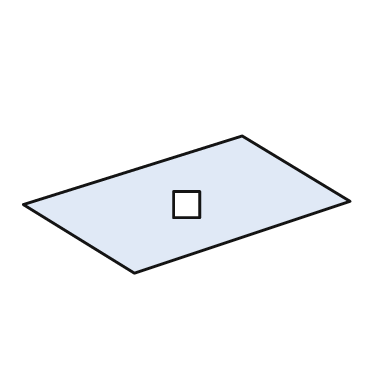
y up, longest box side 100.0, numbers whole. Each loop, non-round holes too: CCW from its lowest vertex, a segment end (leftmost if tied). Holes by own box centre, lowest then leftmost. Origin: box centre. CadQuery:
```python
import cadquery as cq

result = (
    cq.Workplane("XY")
    .moveTo(-16.0, -21.0)
    .lineTo(50.0, 1.0)
    .lineTo(17.0, 21.0)
    .lineTo(-50.0, 0.0)
    .close()
    .moveTo(-4.0, -4.0)
    .lineTo(4.0, -4.0)
    .lineTo(4.0, 4.0)
    .lineTo(-4.0, 4.0)
    .close()
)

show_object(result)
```